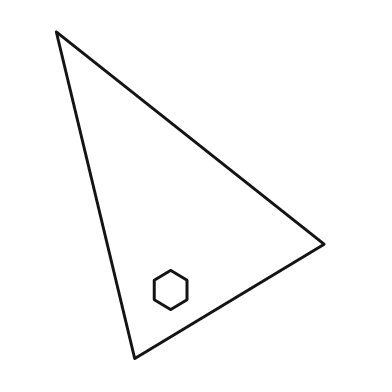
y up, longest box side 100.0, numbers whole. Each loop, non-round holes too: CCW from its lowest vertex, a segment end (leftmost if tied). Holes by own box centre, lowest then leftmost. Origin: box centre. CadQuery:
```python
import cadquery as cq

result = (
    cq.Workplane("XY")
    .moveTo(-17.0, -50.0)
    .lineTo(41.0, -15.0)
    .lineTo(-41.0, 50.0)
    .close()
    .moveTo(-6.0, -35.0)
    .lineTo(-1.0, -32.0)
    .lineTo(-1.0, -26.0)
    .lineTo(-6.0, -23.0)
    .lineTo(-11.0, -26.0)
    .lineTo(-11.0, -32.0)
    .close()
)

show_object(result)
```